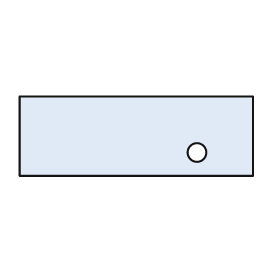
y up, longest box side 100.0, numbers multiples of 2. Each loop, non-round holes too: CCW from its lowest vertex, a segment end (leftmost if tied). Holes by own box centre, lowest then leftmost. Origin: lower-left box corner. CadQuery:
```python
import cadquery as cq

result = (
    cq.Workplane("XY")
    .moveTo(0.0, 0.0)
    .lineTo(100.0, 0.0)
    .lineTo(100.0, 34.0)
    .lineTo(0.0, 34.0)
    .close()
    .moveTo(76.0, 10.0)
    .circle(4.0)
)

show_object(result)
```